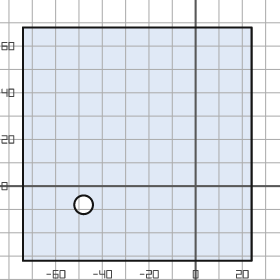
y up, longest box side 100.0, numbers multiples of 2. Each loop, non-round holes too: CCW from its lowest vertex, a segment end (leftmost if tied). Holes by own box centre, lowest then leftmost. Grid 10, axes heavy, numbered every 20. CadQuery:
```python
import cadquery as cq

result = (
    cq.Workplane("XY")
    .moveTo(-74.0, -32.0)
    .lineTo(24.0, -32.0)
    .lineTo(24.0, 68.0)
    .lineTo(-74.0, 68.0)
    .close()
    .moveTo(-48.0, -8.0)
    .circle(4.0)
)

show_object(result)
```